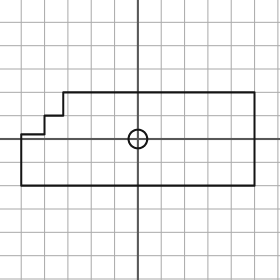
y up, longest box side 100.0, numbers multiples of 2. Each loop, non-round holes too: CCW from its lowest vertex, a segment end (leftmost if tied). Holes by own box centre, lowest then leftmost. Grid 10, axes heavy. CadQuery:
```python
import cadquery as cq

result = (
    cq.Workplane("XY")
    .moveTo(-50.0, -20.0)
    .lineTo(50.0, -20.0)
    .lineTo(50.0, 20.0)
    .lineTo(-32.0, 20.0)
    .lineTo(-32.0, 10.0)
    .lineTo(-40.0, 10.0)
    .lineTo(-40.0, 2.0)
    .lineTo(-50.0, 2.0)
    .close()
    .moveTo(0.0, 0.0)
    .circle(4.0)
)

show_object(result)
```